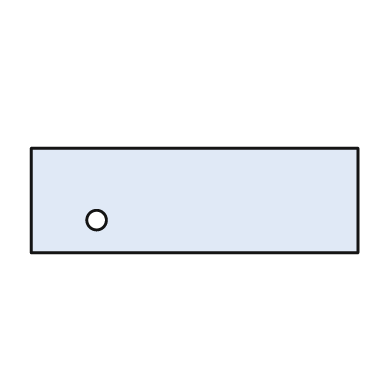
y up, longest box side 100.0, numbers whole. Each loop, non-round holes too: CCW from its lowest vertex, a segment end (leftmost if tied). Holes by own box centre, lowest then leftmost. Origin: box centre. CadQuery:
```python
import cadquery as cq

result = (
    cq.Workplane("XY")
    .moveTo(-50.0, -16.0)
    .lineTo(50.0, -16.0)
    .lineTo(50.0, 16.0)
    .lineTo(-50.0, 16.0)
    .close()
    .moveTo(-30.0, -6.0)
    .circle(3.0)
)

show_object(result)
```